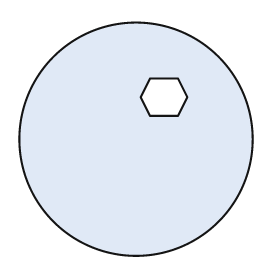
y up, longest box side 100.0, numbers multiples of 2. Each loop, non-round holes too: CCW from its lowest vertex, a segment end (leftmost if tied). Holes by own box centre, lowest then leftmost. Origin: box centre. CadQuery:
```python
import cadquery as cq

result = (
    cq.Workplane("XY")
    .moveTo(0.0, 0.0)
    .circle(50.0)
    .moveTo(6.0, 10.0)
    .lineTo(18.0, 10.0)
    .lineTo(22.0, 18.0)
    .lineTo(18.0, 26.0)
    .lineTo(6.0, 26.0)
    .lineTo(2.0, 18.0)
    .close()
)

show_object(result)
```